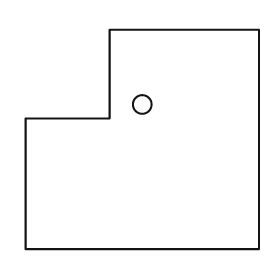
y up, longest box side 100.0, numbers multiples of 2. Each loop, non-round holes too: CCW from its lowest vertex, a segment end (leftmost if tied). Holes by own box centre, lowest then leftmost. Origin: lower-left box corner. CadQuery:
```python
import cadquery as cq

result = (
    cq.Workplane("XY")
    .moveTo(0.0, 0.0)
    .lineTo(100.0, 0.0)
    .lineTo(100.0, 94.0)
    .lineTo(36.0, 94.0)
    .lineTo(36.0, 56.0)
    .lineTo(0.0, 56.0)
    .close()
    .moveTo(50.0, 62.0)
    .circle(4.0)
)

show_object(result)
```